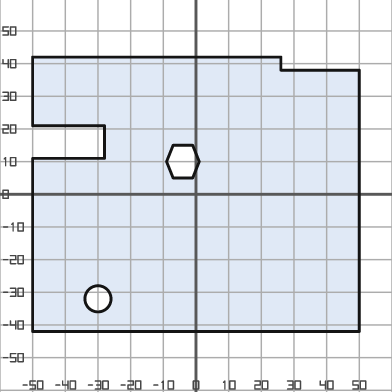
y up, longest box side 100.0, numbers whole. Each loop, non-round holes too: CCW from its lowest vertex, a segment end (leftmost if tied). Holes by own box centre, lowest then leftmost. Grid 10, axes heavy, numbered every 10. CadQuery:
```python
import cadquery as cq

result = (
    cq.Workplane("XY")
    .moveTo(-50.0, -42.0)
    .lineTo(50.0, -42.0)
    .lineTo(50.0, 38.0)
    .lineTo(26.0, 38.0)
    .lineTo(26.0, 42.0)
    .lineTo(-50.0, 42.0)
    .lineTo(-50.0, 21.0)
    .lineTo(-28.0, 21.0)
    .lineTo(-28.0, 11.0)
    .lineTo(-50.0, 11.0)
    .close()
    .moveTo(-30.0, -32.0)
    .circle(4.0)
    .moveTo(-7.0, 5.0)
    .lineTo(-1.0, 5.0)
    .lineTo(1.0, 10.0)
    .lineTo(-1.0, 15.0)
    .lineTo(-7.0, 15.0)
    .lineTo(-9.0, 10.0)
    .close()
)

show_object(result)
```